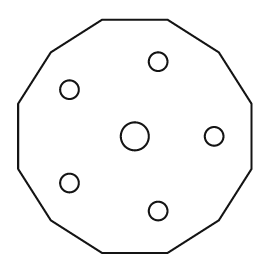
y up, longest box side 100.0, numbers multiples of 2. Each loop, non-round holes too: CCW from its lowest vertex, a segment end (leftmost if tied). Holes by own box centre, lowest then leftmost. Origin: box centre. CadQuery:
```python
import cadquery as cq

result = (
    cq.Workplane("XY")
    .moveTo(-14.0, -50.0)
    .lineTo(14.0, -50.0)
    .lineTo(36.0, -36.0)
    .lineTo(50.0, -14.0)
    .lineTo(50.0, 14.0)
    .lineTo(36.0, 36.0)
    .lineTo(14.0, 50.0)
    .lineTo(-14.0, 50.0)
    .lineTo(-36.0, 36.0)
    .lineTo(-50.0, 14.0)
    .lineTo(-50.0, -14.0)
    .lineTo(-36.0, -36.0)
    .close()
    .moveTo(10.0, -32.0)
    .circle(4.0)
    .moveTo(-28.0, -20.0)
    .circle(4.0)
    .moveTo(0.0, 0.0)
    .circle(6.0)
    .moveTo(34.0, 0.0)
    .circle(4.0)
    .moveTo(-28.0, 20.0)
    .circle(4.0)
    .moveTo(10.0, 32.0)
    .circle(4.0)
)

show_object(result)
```